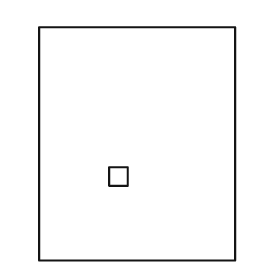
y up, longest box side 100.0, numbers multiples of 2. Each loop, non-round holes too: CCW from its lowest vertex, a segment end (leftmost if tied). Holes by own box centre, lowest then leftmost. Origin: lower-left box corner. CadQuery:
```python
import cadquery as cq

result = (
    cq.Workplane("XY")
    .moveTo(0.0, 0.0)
    .lineTo(84.0, 0.0)
    .lineTo(84.0, 100.0)
    .lineTo(0.0, 100.0)
    .close()
    .moveTo(30.0, 32.0)
    .lineTo(38.0, 32.0)
    .lineTo(38.0, 40.0)
    .lineTo(30.0, 40.0)
    .close()
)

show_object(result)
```